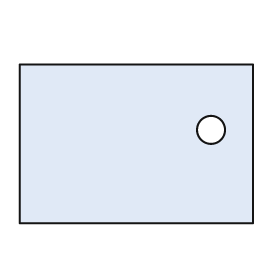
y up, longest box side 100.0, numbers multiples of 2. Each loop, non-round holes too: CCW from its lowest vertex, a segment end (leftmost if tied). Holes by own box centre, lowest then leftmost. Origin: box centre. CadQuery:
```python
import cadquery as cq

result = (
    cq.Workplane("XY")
    .moveTo(-50.0, -34.0)
    .lineTo(50.0, -34.0)
    .lineTo(50.0, 34.0)
    .lineTo(-50.0, 34.0)
    .close()
    .moveTo(32.0, 6.0)
    .circle(6.0)
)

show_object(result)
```